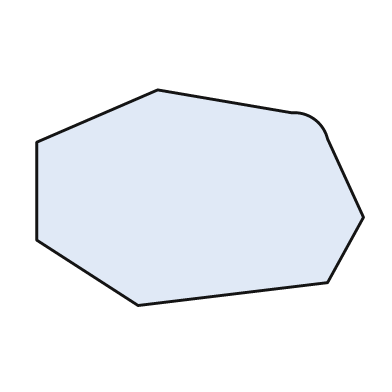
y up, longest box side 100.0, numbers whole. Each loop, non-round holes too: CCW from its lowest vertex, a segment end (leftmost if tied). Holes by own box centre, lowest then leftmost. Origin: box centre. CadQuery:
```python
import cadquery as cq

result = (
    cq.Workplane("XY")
    .moveTo(-19.0, -33.0)
    .lineTo(39.0, -26.0)
    .lineTo(50.0, -6.0)
    .lineTo(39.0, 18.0)
    .threePointArc((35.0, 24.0), (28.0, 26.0))
    .lineTo(-13.0, 33.0)
    .lineTo(-50.0, 17.0)
    .lineTo(-50.0, -13.0)
    .close()
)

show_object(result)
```